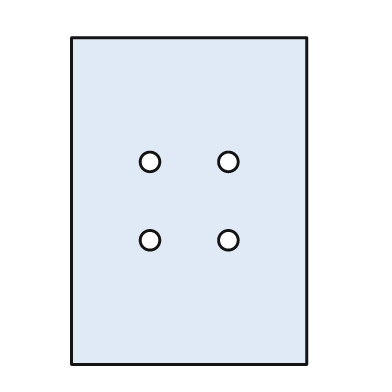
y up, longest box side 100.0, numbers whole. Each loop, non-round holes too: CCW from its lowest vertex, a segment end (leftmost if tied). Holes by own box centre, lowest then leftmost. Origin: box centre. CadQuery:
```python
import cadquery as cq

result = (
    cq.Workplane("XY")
    .moveTo(-36.0, -50.0)
    .lineTo(36.0, -50.0)
    .lineTo(36.0, 50.0)
    .lineTo(-36.0, 50.0)
    .close()
    .moveTo(-12.0, -12.0)
    .circle(3.0)
    .moveTo(12.0, -12.0)
    .circle(3.0)
    .moveTo(-12.0, 12.0)
    .circle(3.0)
    .moveTo(12.0, 12.0)
    .circle(3.0)
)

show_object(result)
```